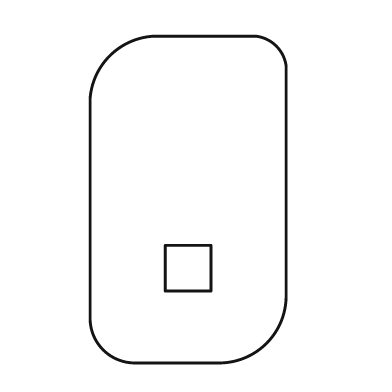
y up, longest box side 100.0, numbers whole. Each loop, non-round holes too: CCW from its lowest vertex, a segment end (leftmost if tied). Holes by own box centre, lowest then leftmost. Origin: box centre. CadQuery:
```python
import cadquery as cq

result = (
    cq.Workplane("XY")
    .moveTo(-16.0, -50.0)
    .lineTo(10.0, -50.0)
    .threePointArc((24.0, -44.0), (30.0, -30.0))
    .lineTo(30.0, 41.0)
    .threePointArc((27.0, 47.0), (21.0, 50.0))
    .lineTo(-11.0, 50.0)
    .threePointArc((-24.0, 44.0), (-30.0, 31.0))
    .lineTo(-30.0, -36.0)
    .threePointArc((-26.0, -46.0), (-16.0, -50.0))
    .close()
    .moveTo(-7.0, -28.0)
    .lineTo(7.0, -28.0)
    .lineTo(7.0, -14.0)
    .lineTo(-7.0, -14.0)
    .close()
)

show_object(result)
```